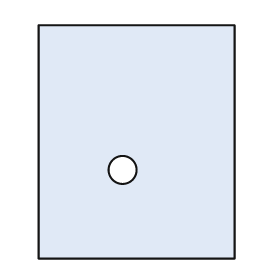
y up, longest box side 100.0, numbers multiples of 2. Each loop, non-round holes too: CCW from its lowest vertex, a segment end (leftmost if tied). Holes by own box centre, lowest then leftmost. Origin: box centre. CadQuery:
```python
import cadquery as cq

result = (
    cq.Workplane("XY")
    .moveTo(-42.0, -50.0)
    .lineTo(42.0, -50.0)
    .lineTo(42.0, 50.0)
    .lineTo(-42.0, 50.0)
    .close()
    .moveTo(-6.0, -12.0)
    .circle(6.0)
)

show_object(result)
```